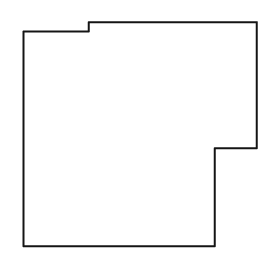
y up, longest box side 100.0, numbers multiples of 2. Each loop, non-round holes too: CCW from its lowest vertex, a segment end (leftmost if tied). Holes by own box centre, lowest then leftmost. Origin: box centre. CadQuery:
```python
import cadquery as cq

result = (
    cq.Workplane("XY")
    .moveTo(-50.0, -48.0)
    .lineTo(32.0, -48.0)
    .lineTo(32.0, -6.0)
    .lineTo(50.0, -6.0)
    .lineTo(50.0, 48.0)
    .lineTo(-22.0, 48.0)
    .lineTo(-22.0, 44.0)
    .lineTo(-50.0, 44.0)
    .close()
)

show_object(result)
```